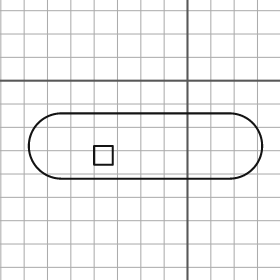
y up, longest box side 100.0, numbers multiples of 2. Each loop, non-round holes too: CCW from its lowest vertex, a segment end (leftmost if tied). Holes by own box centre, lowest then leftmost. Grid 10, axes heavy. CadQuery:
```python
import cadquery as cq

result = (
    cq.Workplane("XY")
    .moveTo(-54.0, -42.0)
    .lineTo(18.0, -42.0)
    .threePointArc((32.0, -28.0), (18.0, -14.0))
    .lineTo(-54.0, -14.0)
    .threePointArc((-68.0, -28.0), (-54.0, -42.0))
    .close()
    .moveTo(-40.0, -36.0)
    .lineTo(-32.0, -36.0)
    .lineTo(-32.0, -28.0)
    .lineTo(-40.0, -28.0)
    .close()
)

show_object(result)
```